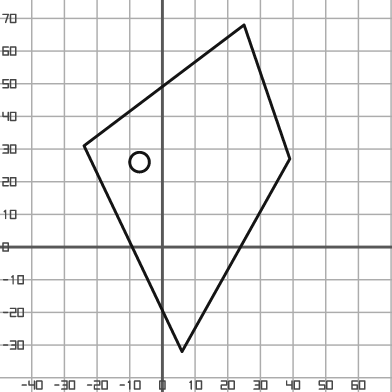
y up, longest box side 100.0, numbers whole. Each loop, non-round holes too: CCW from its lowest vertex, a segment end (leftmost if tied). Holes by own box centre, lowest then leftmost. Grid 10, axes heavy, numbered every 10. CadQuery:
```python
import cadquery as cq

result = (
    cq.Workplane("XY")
    .moveTo(6.0, -32.0)
    .lineTo(39.0, 27.0)
    .lineTo(25.0, 68.0)
    .lineTo(-24.0, 31.0)
    .close()
    .moveTo(-7.0, 26.0)
    .circle(3.0)
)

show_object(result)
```